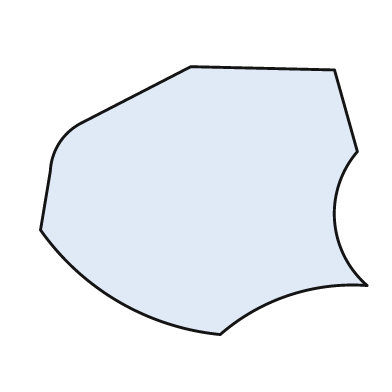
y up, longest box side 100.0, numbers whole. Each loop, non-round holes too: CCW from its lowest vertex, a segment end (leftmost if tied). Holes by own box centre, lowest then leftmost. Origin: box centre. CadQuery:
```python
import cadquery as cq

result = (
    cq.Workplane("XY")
    .moveTo(5.0, -41.0)
    .threePointArc((26.0, -29.0), (50.0, -26.0))
    .threePointArc((40.0, -6.0), (47.0, 15.0))
    .lineTo(40.0, 40.0)
    .lineTo(-4.0, 41.0)
    .lineTo(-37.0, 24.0)
    .threePointArc((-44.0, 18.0), (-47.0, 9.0))
    .lineTo(-50.0, -9.0)
    .threePointArc((-26.0, -31.0), (5.0, -41.0))
    .close()
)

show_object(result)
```